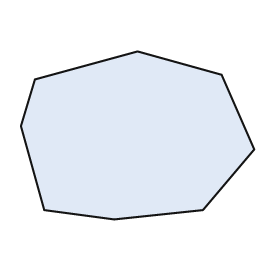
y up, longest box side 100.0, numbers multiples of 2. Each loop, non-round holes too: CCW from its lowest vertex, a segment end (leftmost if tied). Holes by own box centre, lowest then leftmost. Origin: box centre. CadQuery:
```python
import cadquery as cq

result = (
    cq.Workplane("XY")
    .moveTo(-10.0, -36.0)
    .lineTo(28.0, -32.0)
    .lineTo(50.0, -6.0)
    .lineTo(36.0, 26.0)
    .lineTo(0.0, 36.0)
    .lineTo(-44.0, 24.0)
    .lineTo(-50.0, 4.0)
    .lineTo(-40.0, -32.0)
    .close()
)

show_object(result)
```